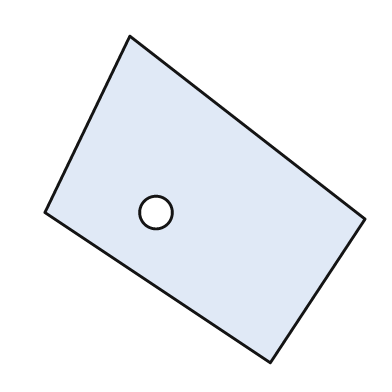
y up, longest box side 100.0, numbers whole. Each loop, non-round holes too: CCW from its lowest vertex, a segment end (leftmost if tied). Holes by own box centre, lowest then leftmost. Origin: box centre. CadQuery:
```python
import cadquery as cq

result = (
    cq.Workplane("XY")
    .moveTo(20.0, -50.0)
    .lineTo(49.0, -6.0)
    .lineTo(-23.0, 50.0)
    .lineTo(-49.0, -4.0)
    .close()
    .moveTo(-15.0, -4.0)
    .circle(5.0)
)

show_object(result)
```